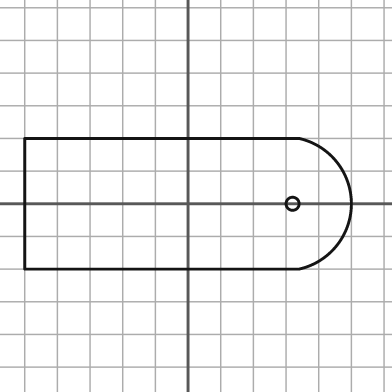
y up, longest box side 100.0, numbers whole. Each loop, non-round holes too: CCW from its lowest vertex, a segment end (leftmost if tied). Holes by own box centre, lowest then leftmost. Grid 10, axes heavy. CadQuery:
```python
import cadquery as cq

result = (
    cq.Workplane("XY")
    .moveTo(-50.0, -20.0)
    .lineTo(34.0, -20.0)
    .threePointArc((50.0, 0.0), (34.0, 20.0))
    .lineTo(-50.0, 20.0)
    .close()
    .moveTo(32.0, 0.0)
    .circle(2.0)
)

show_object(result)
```